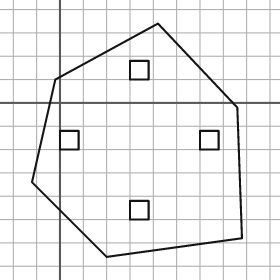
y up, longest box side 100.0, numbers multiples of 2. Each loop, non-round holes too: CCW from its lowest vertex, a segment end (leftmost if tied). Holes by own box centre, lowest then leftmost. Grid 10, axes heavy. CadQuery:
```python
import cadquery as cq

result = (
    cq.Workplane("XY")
    .moveTo(20.0, -66.0)
    .lineTo(78.0, -58.0)
    .lineTo(76.0, -2.0)
    .lineTo(42.0, 34.0)
    .lineTo(-2.0, 10.0)
    .lineTo(-12.0, -34.0)
    .close()
    .moveTo(30.0, -50.0)
    .lineTo(38.0, -50.0)
    .lineTo(38.0, -42.0)
    .lineTo(30.0, -42.0)
    .close()
    .moveTo(0.0, -20.0)
    .lineTo(8.0, -20.0)
    .lineTo(8.0, -12.0)
    .lineTo(0.0, -12.0)
    .close()
    .moveTo(60.0, -20.0)
    .lineTo(68.0, -20.0)
    .lineTo(68.0, -12.0)
    .lineTo(60.0, -12.0)
    .close()
    .moveTo(30.0, 10.0)
    .lineTo(38.0, 10.0)
    .lineTo(38.0, 18.0)
    .lineTo(30.0, 18.0)
    .close()
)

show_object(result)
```